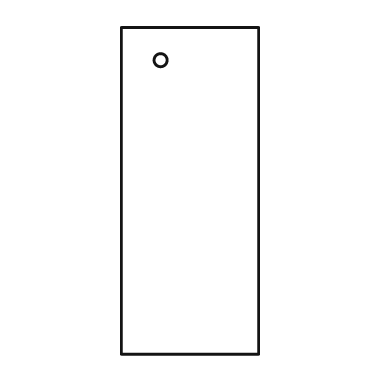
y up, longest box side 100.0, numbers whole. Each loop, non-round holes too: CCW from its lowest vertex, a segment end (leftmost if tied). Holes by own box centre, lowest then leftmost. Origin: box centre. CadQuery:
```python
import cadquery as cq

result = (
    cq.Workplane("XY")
    .moveTo(-21.0, -50.0)
    .lineTo(21.0, -50.0)
    .lineTo(21.0, 50.0)
    .lineTo(-21.0, 50.0)
    .close()
    .moveTo(-9.0, 40.0)
    .circle(2.0)
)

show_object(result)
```